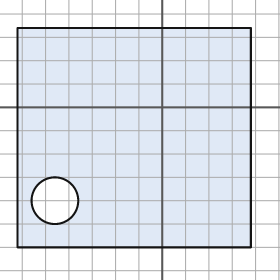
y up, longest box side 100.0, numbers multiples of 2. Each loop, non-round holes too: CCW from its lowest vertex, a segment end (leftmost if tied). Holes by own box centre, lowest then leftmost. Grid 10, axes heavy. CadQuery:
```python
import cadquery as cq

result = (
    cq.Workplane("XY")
    .moveTo(-62.0, -60.0)
    .lineTo(38.0, -60.0)
    .lineTo(38.0, 34.0)
    .lineTo(-62.0, 34.0)
    .close()
    .moveTo(-46.0, -40.0)
    .circle(10.0)
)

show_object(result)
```